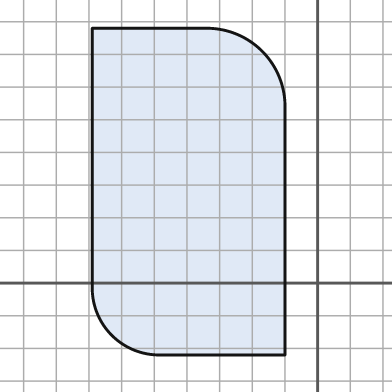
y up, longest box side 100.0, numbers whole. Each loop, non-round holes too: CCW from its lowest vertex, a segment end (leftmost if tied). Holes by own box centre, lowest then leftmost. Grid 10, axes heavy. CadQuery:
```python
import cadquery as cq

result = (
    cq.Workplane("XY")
    .moveTo(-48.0, -22.0)
    .lineTo(-10.0, -22.0)
    .lineTo(-10.0, 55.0)
    .threePointArc((-17.0, 71.0), (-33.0, 78.0))
    .lineTo(-69.0, 78.0)
    .lineTo(-69.0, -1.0)
    .threePointArc((-63.0, -16.0), (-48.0, -22.0))
    .close()
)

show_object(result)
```